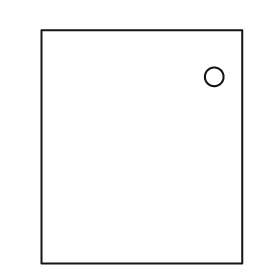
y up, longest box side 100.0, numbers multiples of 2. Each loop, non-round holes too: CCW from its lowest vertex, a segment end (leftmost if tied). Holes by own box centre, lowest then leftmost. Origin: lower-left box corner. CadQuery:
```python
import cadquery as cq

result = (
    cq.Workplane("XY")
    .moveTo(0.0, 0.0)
    .lineTo(86.0, 0.0)
    .lineTo(86.0, 100.0)
    .lineTo(0.0, 100.0)
    .close()
    .moveTo(74.0, 80.0)
    .circle(4.0)
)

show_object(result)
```